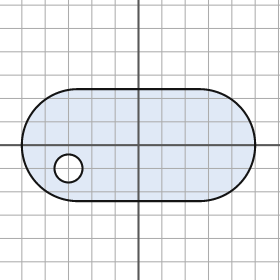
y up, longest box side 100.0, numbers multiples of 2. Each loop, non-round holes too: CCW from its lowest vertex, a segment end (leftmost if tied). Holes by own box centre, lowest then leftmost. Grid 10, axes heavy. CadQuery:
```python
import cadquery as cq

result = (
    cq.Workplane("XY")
    .moveTo(-26.0, -24.0)
    .lineTo(26.0, -24.0)
    .threePointArc((50.0, 0.0), (26.0, 24.0))
    .lineTo(-26.0, 24.0)
    .threePointArc((-50.0, 0.0), (-26.0, -24.0))
    .close()
    .moveTo(-30.0, -10.0)
    .circle(6.0)
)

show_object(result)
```